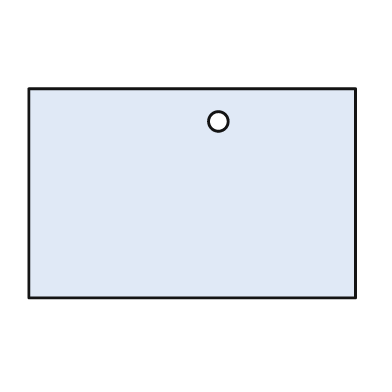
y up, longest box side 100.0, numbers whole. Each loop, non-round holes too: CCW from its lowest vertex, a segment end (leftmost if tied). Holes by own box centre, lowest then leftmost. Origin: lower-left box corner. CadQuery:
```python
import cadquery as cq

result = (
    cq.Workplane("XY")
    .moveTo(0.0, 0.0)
    .lineTo(100.0, 0.0)
    .lineTo(100.0, 64.0)
    .lineTo(0.0, 64.0)
    .close()
    .moveTo(58.0, 54.0)
    .circle(3.0)
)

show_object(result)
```